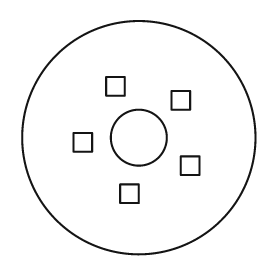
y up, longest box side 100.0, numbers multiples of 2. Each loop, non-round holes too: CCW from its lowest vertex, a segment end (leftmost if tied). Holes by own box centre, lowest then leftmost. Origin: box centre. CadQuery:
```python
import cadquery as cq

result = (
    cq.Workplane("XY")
    .moveTo(0.0, 0.0)
    .circle(50.0)
    .moveTo(-8.0, -28.0)
    .lineTo(0.0, -28.0)
    .lineTo(0.0, -20.0)
    .lineTo(-8.0, -20.0)
    .close()
    .moveTo(18.0, -16.0)
    .lineTo(26.0, -16.0)
    .lineTo(26.0, -8.0)
    .lineTo(18.0, -8.0)
    .close()
    .moveTo(-28.0, -6.0)
    .lineTo(-20.0, -6.0)
    .lineTo(-20.0, 2.0)
    .lineTo(-28.0, 2.0)
    .close()
    .moveTo(0.0, 0.0)
    .circle(12.0)
    .moveTo(14.0, 12.0)
    .lineTo(22.0, 12.0)
    .lineTo(22.0, 20.0)
    .lineTo(14.0, 20.0)
    .close()
    .moveTo(-14.0, 18.0)
    .lineTo(-6.0, 18.0)
    .lineTo(-6.0, 26.0)
    .lineTo(-14.0, 26.0)
    .close()
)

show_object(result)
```